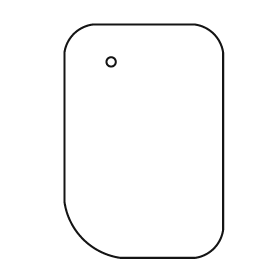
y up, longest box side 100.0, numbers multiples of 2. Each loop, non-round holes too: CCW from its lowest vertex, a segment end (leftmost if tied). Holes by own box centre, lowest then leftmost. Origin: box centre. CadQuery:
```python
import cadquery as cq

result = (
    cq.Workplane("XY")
    .moveTo(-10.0, -50.0)
    .lineTo(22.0, -50.0)
    .threePointArc((30.0, -46.0), (34.0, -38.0))
    .lineTo(34.0, 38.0)
    .threePointArc((30.0, 46.0), (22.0, 50.0))
    .lineTo(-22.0, 50.0)
    .threePointArc((-30.0, 46.0), (-34.0, 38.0))
    .lineTo(-34.0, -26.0)
    .threePointArc((-26.0, -42.0), (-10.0, -50.0))
    .close()
    .moveTo(-14.0, 34.0)
    .circle(2.0)
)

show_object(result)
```